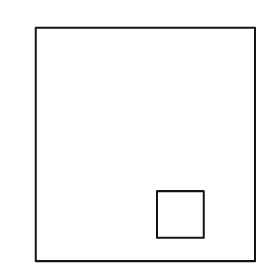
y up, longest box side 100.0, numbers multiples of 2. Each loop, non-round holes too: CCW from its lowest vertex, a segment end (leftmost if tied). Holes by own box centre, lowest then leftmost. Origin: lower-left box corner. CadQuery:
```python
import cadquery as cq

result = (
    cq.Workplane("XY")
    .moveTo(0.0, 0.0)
    .lineTo(94.0, 0.0)
    .lineTo(94.0, 100.0)
    .lineTo(0.0, 100.0)
    .close()
    .moveTo(52.0, 10.0)
    .lineTo(72.0, 10.0)
    .lineTo(72.0, 30.0)
    .lineTo(52.0, 30.0)
    .close()
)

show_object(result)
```